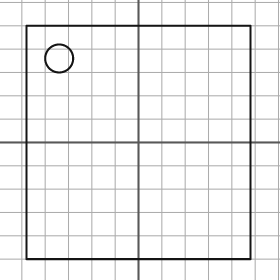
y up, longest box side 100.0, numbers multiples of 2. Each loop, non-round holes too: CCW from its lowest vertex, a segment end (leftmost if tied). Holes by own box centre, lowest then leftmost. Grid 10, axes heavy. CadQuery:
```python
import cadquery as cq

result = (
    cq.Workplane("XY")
    .moveTo(-48.0, -50.0)
    .lineTo(48.0, -50.0)
    .lineTo(48.0, 50.0)
    .lineTo(-48.0, 50.0)
    .close()
    .moveTo(-34.0, 36.0)
    .circle(6.0)
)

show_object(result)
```